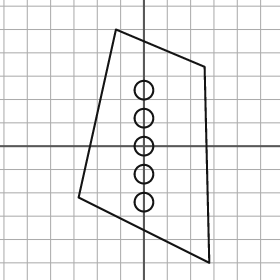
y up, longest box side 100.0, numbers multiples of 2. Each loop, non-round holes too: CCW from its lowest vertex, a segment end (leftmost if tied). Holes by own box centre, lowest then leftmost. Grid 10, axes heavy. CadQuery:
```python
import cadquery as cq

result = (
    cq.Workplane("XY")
    .moveTo(28.0, -50.0)
    .lineTo(26.0, 34.0)
    .lineTo(-12.0, 50.0)
    .lineTo(-28.0, -22.0)
    .close()
    .moveTo(0.0, -24.0)
    .circle(4.0)
    .moveTo(0.0, -12.0)
    .circle(4.0)
    .moveTo(0.0, 0.0)
    .circle(4.0)
    .moveTo(0.0, 12.0)
    .circle(4.0)
    .moveTo(0.0, 24.0)
    .circle(4.0)
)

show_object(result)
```